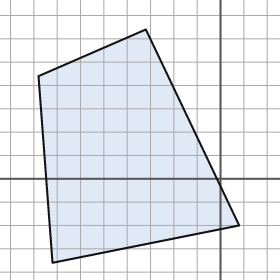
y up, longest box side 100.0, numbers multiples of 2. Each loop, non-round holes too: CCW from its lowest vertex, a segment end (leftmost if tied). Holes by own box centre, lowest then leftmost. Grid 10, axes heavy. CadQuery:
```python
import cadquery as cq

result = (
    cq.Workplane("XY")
    .moveTo(-72.0, -36.0)
    .lineTo(8.0, -20.0)
    .lineTo(-32.0, 64.0)
    .lineTo(-78.0, 44.0)
    .close()
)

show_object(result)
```